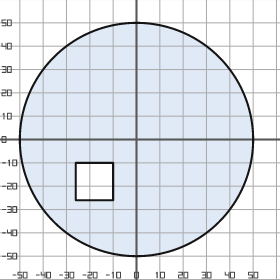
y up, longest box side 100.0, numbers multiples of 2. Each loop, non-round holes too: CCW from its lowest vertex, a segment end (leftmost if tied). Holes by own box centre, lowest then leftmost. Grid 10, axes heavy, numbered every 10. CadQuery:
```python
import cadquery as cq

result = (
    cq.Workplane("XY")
    .moveTo(0.0, 0.0)
    .circle(50.0)
    .moveTo(-26.0, -26.0)
    .lineTo(-10.0, -26.0)
    .lineTo(-10.0, -10.0)
    .lineTo(-26.0, -10.0)
    .close()
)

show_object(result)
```